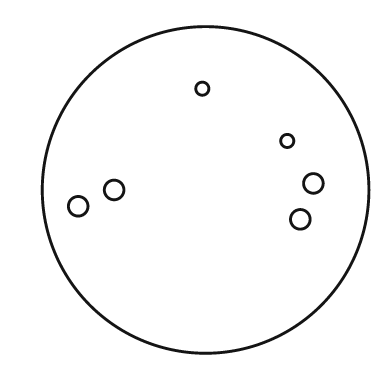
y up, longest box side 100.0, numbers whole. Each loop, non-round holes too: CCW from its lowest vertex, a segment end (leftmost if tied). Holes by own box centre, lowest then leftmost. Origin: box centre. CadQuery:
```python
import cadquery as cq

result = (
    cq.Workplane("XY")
    .moveTo(0.0, 0.0)
    .circle(50.0)
    .moveTo(29.0, -9.0)
    .circle(3.0)
    .moveTo(-39.0, -5.0)
    .circle(3.0)
    .moveTo(-28.0, 0.0)
    .circle(3.0)
    .moveTo(33.0, 2.0)
    .circle(3.0)
    .moveTo(25.0, 15.0)
    .circle(2.0)
    .moveTo(-1.0, 31.0)
    .circle(2.0)
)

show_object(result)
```